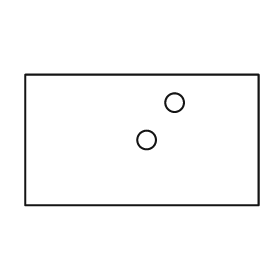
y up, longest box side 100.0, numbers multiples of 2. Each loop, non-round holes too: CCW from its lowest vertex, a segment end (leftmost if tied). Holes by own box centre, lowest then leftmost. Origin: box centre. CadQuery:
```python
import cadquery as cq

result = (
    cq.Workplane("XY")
    .moveTo(-50.0, -28.0)
    .lineTo(50.0, -28.0)
    .lineTo(50.0, 28.0)
    .lineTo(-50.0, 28.0)
    .close()
    .moveTo(2.0, 0.0)
    .circle(4.0)
    .moveTo(14.0, 16.0)
    .circle(4.0)
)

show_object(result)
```